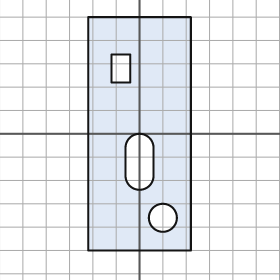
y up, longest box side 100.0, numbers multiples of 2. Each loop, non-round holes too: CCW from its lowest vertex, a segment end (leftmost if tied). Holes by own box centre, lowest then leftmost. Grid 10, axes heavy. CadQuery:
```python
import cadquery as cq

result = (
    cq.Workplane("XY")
    .moveTo(-22.0, -50.0)
    .lineTo(22.0, -50.0)
    .lineTo(22.0, 50.0)
    .lineTo(-22.0, 50.0)
    .close()
    .moveTo(10.0, -36.0)
    .circle(6.0)
    .moveTo(-6.0, -18.0)
    .threePointArc((0.0, -24.0), (6.0, -18.0))
    .lineTo(6.0, -6.0)
    .threePointArc((0.0, 0.0), (-6.0, -6.0))
    .close()
    .moveTo(-12.0, 22.0)
    .lineTo(-4.0, 22.0)
    .lineTo(-4.0, 34.0)
    .lineTo(-12.0, 34.0)
    .close()
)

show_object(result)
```